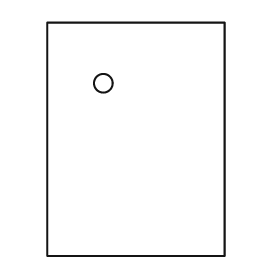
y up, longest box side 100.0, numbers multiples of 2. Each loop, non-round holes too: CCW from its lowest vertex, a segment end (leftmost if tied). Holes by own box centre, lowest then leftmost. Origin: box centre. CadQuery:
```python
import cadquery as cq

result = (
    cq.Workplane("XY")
    .moveTo(-38.0, -50.0)
    .lineTo(38.0, -50.0)
    .lineTo(38.0, 50.0)
    .lineTo(-38.0, 50.0)
    .close()
    .moveTo(-14.0, 24.0)
    .circle(4.0)
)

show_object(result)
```